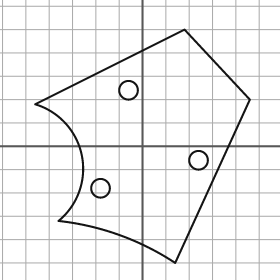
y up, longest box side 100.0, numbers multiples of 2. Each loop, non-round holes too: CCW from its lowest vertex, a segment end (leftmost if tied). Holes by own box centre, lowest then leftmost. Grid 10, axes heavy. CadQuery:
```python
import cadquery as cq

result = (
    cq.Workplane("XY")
    .moveTo(14.0, -50.0)
    .lineTo(46.0, 20.0)
    .lineTo(18.0, 50.0)
    .lineTo(-46.0, 18.0)
    .threePointArc((-26.0, -4.0), (-36.0, -32.0))
    .threePointArc((-10.0, -38.0), (14.0, -50.0))
    .close()
    .moveTo(-18.0, -18.0)
    .circle(4.0)
    .moveTo(24.0, -6.0)
    .circle(4.0)
    .moveTo(-6.0, 24.0)
    .circle(4.0)
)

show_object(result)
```